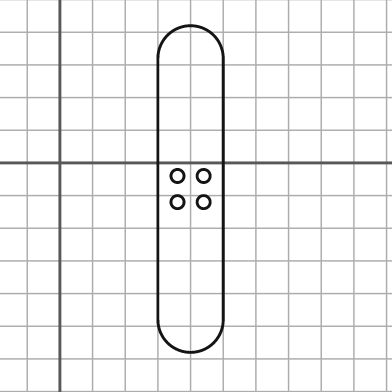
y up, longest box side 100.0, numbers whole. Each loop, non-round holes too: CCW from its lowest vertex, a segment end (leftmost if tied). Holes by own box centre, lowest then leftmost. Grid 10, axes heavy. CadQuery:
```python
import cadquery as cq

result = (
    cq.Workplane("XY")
    .moveTo(30.0, -48.0)
    .threePointArc((40.0, -58.0), (50.0, -48.0))
    .lineTo(50.0, 32.0)
    .threePointArc((40.0, 42.0), (30.0, 32.0))
    .close()
    .moveTo(36.0, -12.0)
    .circle(2.0)
    .moveTo(44.0, -12.0)
    .circle(2.0)
    .moveTo(36.0, -4.0)
    .circle(2.0)
    .moveTo(44.0, -4.0)
    .circle(2.0)
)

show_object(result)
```